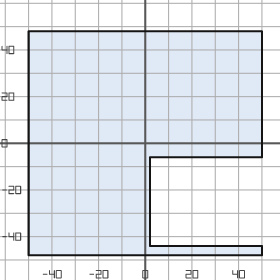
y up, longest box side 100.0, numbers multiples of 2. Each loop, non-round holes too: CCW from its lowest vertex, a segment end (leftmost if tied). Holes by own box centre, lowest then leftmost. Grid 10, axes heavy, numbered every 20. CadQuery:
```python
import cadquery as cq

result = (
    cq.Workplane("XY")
    .moveTo(-50.0, -48.0)
    .lineTo(50.0, -48.0)
    .lineTo(50.0, -44.0)
    .lineTo(2.0, -44.0)
    .lineTo(2.0, -6.0)
    .lineTo(50.0, -6.0)
    .lineTo(50.0, 48.0)
    .lineTo(-50.0, 48.0)
    .close()
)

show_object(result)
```